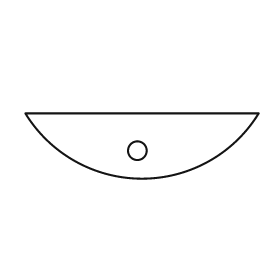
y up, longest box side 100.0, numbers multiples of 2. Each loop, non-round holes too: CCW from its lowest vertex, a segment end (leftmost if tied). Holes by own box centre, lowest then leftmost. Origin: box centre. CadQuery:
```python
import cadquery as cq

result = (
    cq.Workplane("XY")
    .moveTo(-50.0, 14.0)
    .threePointArc((0.0, -14.0), (50.0, 14.0))
    .close()
    .moveTo(-2.0, -2.0)
    .circle(4.0)
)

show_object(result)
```